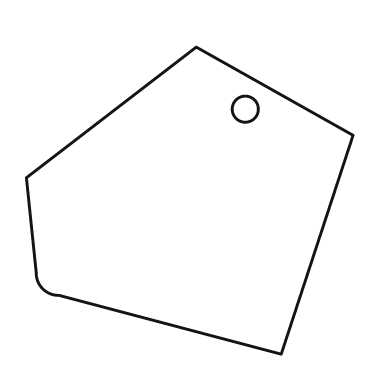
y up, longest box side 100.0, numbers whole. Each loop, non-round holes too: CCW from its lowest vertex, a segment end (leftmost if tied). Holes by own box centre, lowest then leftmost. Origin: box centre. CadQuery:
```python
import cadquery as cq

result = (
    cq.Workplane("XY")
    .moveTo(28.0, -47.0)
    .lineTo(50.0, 20.0)
    .lineTo(2.0, 47.0)
    .lineTo(-50.0, 7.0)
    .lineTo(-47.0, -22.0)
    .threePointArc((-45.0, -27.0), (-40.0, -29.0))
    .close()
    .moveTo(17.0, 28.0)
    .circle(4.0)
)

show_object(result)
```